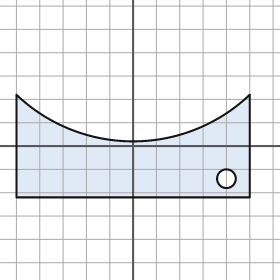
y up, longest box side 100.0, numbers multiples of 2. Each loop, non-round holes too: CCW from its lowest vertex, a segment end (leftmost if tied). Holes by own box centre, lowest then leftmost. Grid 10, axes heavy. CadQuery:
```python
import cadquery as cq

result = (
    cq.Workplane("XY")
    .moveTo(-50.0, -22.0)
    .lineTo(50.0, -22.0)
    .lineTo(50.0, 22.0)
    .threePointArc((0.0, 2.0), (-50.0, 22.0))
    .close()
    .moveTo(40.0, -14.0)
    .circle(4.0)
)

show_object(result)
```